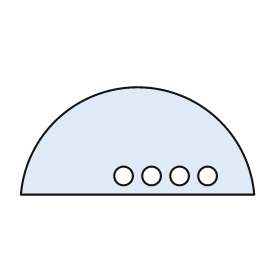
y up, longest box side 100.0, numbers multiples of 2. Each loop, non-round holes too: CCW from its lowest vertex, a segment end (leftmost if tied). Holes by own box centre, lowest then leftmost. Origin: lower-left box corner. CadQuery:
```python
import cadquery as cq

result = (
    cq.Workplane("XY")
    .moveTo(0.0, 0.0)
    .lineTo(100.0, 0.0)
    .threePointArc((50.0, 46.0), (0.0, 0.0))
    .close()
    .moveTo(44.0, 8.0)
    .circle(4.0)
    .moveTo(56.0, 8.0)
    .circle(4.0)
    .moveTo(68.0, 8.0)
    .circle(4.0)
    .moveTo(80.0, 8.0)
    .circle(4.0)
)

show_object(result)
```